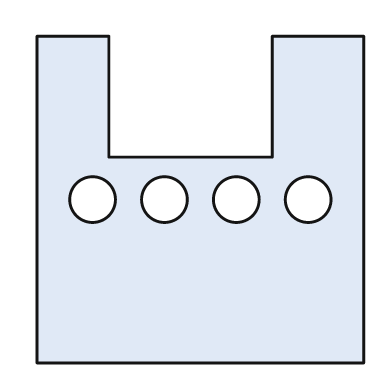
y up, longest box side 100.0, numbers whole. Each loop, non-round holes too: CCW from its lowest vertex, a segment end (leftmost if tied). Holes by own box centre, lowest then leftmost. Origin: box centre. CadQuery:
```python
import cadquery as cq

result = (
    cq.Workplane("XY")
    .moveTo(-50.0, -50.0)
    .lineTo(50.0, -50.0)
    .lineTo(50.0, 50.0)
    .lineTo(22.0, 50.0)
    .lineTo(22.0, 13.0)
    .lineTo(-28.0, 13.0)
    .lineTo(-28.0, 50.0)
    .lineTo(-50.0, 50.0)
    .close()
    .moveTo(-33.0, 0.0)
    .circle(7.0)
    .moveTo(-11.0, 0.0)
    .circle(7.0)
    .moveTo(11.0, 0.0)
    .circle(7.0)
    .moveTo(33.0, 0.0)
    .circle(7.0)
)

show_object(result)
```